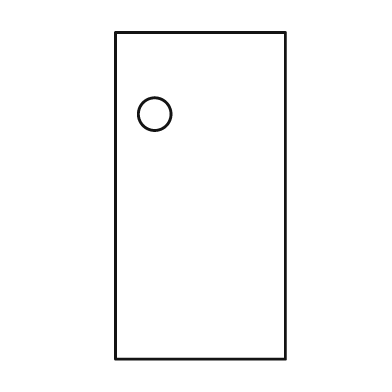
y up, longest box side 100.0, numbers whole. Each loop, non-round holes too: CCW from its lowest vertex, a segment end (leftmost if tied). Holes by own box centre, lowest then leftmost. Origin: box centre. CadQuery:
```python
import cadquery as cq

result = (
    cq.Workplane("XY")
    .moveTo(-26.0, -50.0)
    .lineTo(26.0, -50.0)
    .lineTo(26.0, 50.0)
    .lineTo(-26.0, 50.0)
    .close()
    .moveTo(-14.0, 25.0)
    .circle(5.0)
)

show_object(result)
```